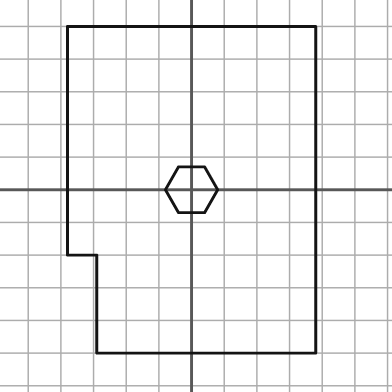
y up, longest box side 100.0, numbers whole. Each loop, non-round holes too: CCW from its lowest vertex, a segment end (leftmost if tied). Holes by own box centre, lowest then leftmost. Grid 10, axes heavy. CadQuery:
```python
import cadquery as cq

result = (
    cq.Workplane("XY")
    .moveTo(-29.0, -50.0)
    .lineTo(38.0, -50.0)
    .lineTo(38.0, 50.0)
    .lineTo(-38.0, 50.0)
    .lineTo(-38.0, -20.0)
    .lineTo(-29.0, -20.0)
    .close()
    .moveTo(-4.0, -7.0)
    .lineTo(4.0, -7.0)
    .lineTo(8.0, 0.0)
    .lineTo(4.0, 7.0)
    .lineTo(-4.0, 7.0)
    .lineTo(-8.0, 0.0)
    .close()
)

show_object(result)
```